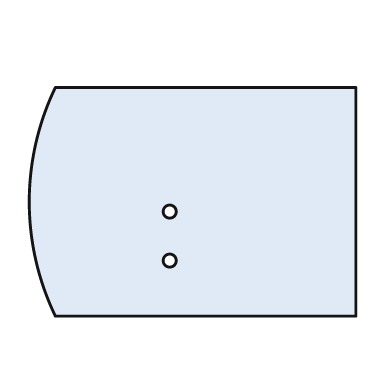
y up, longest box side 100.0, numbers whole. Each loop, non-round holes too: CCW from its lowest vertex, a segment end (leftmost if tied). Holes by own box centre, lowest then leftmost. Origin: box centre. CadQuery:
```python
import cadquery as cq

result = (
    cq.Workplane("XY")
    .moveTo(-42.0, -35.0)
    .lineTo(50.0, -35.0)
    .lineTo(50.0, 35.0)
    .lineTo(-42.0, 35.0)
    .threePointArc((-50.0, 0.0), (-42.0, -35.0))
    .close()
    .moveTo(-7.0, -18.0)
    .circle(2.0)
    .moveTo(-7.0, -3.0)
    .circle(2.0)
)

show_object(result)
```